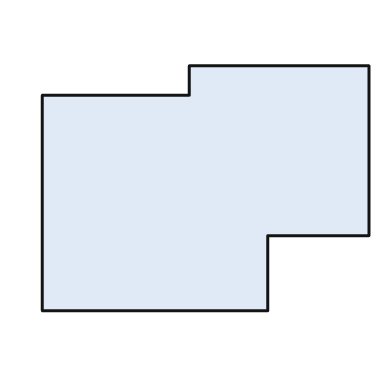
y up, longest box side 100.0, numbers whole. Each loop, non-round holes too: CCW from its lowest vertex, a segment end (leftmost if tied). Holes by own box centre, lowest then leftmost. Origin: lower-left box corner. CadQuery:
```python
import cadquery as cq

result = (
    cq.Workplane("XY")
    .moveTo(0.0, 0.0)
    .lineTo(69.0, 0.0)
    .lineTo(69.0, 23.0)
    .lineTo(100.0, 23.0)
    .lineTo(100.0, 75.0)
    .lineTo(45.0, 75.0)
    .lineTo(45.0, 66.0)
    .lineTo(0.0, 66.0)
    .close()
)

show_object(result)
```